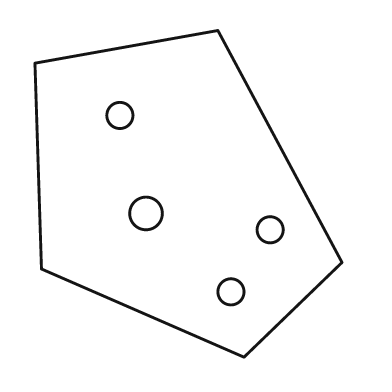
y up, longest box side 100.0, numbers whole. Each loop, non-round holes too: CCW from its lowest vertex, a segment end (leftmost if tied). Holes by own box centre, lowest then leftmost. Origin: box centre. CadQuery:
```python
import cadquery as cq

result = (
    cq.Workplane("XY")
    .moveTo(17.0, -50.0)
    .lineTo(47.0, -21.0)
    .lineTo(9.0, 50.0)
    .lineTo(-47.0, 40.0)
    .lineTo(-45.0, -23.0)
    .close()
    .moveTo(13.0, -30.0)
    .circle(4.0)
    .moveTo(25.0, -11.0)
    .circle(4.0)
    .moveTo(-13.0, -6.0)
    .circle(5.0)
    .moveTo(-21.0, 24.0)
    .circle(4.0)
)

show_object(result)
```